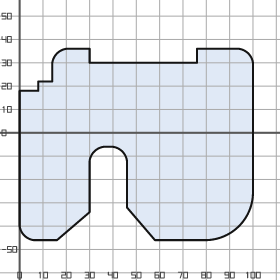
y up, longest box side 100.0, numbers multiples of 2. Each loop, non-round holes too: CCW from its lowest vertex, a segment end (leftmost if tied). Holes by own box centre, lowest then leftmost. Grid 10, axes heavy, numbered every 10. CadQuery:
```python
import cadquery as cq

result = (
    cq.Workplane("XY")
    .moveTo(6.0, -46.0)
    .lineTo(16.0, -46.0)
    .lineTo(30.0, -34.0)
    .lineTo(30.0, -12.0)
    .threePointArc((32.0, -8.0), (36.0, -6.0))
    .lineTo(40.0, -6.0)
    .threePointArc((44.0, -8.0), (46.0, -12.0))
    .lineTo(46.0, -32.0)
    .lineTo(58.0, -46.0)
    .lineTo(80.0, -46.0)
    .threePointArc((94.0, -40.0), (100.0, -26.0))
    .lineTo(100.0, 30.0)
    .threePointArc((98.0, 34.0), (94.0, 36.0))
    .lineTo(76.0, 36.0)
    .lineTo(76.0, 30.0)
    .lineTo(30.0, 30.0)
    .lineTo(30.0, 36.0)
    .lineTo(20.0, 36.0)
    .threePointArc((16.0, 34.0), (14.0, 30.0))
    .lineTo(14.0, 22.0)
    .lineTo(8.0, 22.0)
    .lineTo(8.0, 18.0)
    .lineTo(0.0, 18.0)
    .lineTo(0.0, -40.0)
    .threePointArc((2.0, -44.0), (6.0, -46.0))
    .close()
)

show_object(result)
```